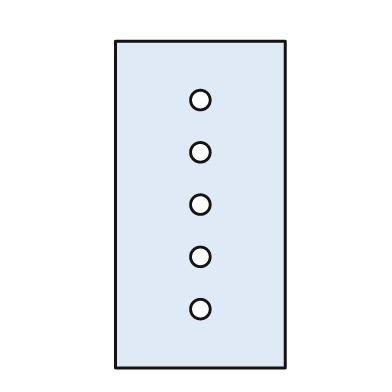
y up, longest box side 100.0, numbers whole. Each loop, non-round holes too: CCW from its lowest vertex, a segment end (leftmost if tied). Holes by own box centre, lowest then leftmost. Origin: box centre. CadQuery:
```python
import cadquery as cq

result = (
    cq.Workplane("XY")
    .moveTo(-26.0, -50.0)
    .lineTo(26.0, -50.0)
    .lineTo(26.0, 50.0)
    .lineTo(-26.0, 50.0)
    .close()
    .moveTo(0.0, -32.0)
    .circle(3.0)
    .moveTo(0.0, -16.0)
    .circle(3.0)
    .moveTo(0.0, 0.0)
    .circle(3.0)
    .moveTo(0.0, 16.0)
    .circle(3.0)
    .moveTo(0.0, 32.0)
    .circle(3.0)
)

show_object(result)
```